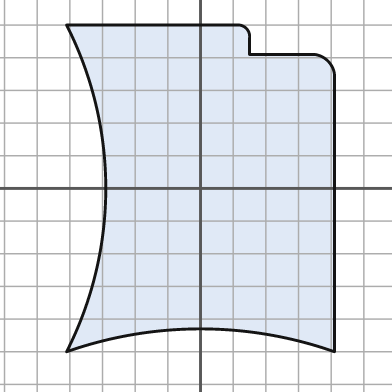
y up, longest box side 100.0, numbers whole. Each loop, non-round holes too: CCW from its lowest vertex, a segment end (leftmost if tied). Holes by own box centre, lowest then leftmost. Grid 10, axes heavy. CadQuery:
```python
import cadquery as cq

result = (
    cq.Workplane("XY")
    .moveTo(-41.0, -50.0)
    .threePointArc((0.0, -43.0), (41.0, -50.0))
    .lineTo(41.0, 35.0)
    .threePointArc((39.0, 39.0), (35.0, 41.0))
    .lineTo(15.0, 41.0)
    .lineTo(15.0, 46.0)
    .threePointArc((14.0, 49.0), (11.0, 50.0))
    .lineTo(-41.0, 50.0)
    .threePointArc((-29.0, 0.0), (-41.0, -50.0))
    .close()
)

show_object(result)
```